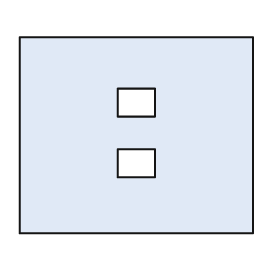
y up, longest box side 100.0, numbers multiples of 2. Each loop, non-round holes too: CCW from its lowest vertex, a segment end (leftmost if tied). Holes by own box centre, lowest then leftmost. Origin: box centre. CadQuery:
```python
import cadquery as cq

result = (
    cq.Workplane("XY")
    .moveTo(-50.0, -42.0)
    .lineTo(50.0, -42.0)
    .lineTo(50.0, 42.0)
    .lineTo(-50.0, 42.0)
    .close()
    .moveTo(-8.0, -18.0)
    .lineTo(8.0, -18.0)
    .lineTo(8.0, -6.0)
    .lineTo(-8.0, -6.0)
    .close()
    .moveTo(-8.0, 8.0)
    .lineTo(8.0, 8.0)
    .lineTo(8.0, 20.0)
    .lineTo(-8.0, 20.0)
    .close()
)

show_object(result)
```